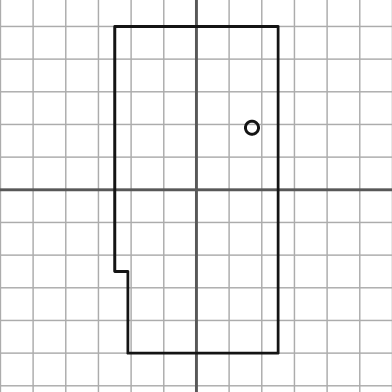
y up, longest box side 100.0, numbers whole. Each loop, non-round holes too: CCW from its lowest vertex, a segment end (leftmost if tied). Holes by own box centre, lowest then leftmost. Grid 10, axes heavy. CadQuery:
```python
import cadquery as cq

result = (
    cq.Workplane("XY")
    .moveTo(-21.0, -50.0)
    .lineTo(25.0, -50.0)
    .lineTo(25.0, 50.0)
    .lineTo(-25.0, 50.0)
    .lineTo(-25.0, -25.0)
    .lineTo(-21.0, -25.0)
    .close()
    .moveTo(17.0, 19.0)
    .circle(2.0)
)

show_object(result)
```